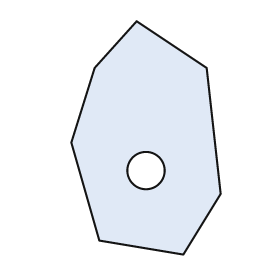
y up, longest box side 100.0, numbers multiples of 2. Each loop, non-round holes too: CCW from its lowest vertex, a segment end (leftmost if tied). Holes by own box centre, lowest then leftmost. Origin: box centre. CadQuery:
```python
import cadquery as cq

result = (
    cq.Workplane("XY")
    .moveTo(16.0, -50.0)
    .lineTo(32.0, -24.0)
    .lineTo(26.0, 30.0)
    .lineTo(-4.0, 50.0)
    .lineTo(-22.0, 30.0)
    .lineTo(-32.0, -2.0)
    .lineTo(-20.0, -44.0)
    .close()
    .moveTo(0.0, -14.0)
    .circle(8.0)
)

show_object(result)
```